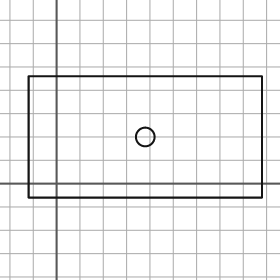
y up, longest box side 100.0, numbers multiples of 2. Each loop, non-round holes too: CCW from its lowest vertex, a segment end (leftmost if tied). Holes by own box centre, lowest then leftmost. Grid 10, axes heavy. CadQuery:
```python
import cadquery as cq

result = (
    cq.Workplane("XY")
    .moveTo(-12.0, -6.0)
    .lineTo(88.0, -6.0)
    .lineTo(88.0, 46.0)
    .lineTo(-12.0, 46.0)
    .close()
    .moveTo(38.0, 20.0)
    .circle(4.0)
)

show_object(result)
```